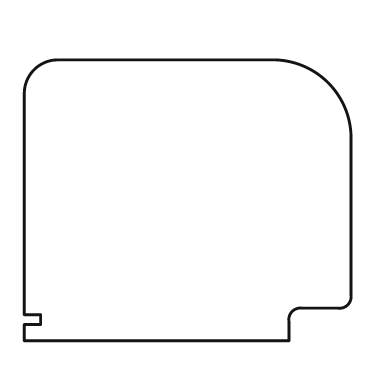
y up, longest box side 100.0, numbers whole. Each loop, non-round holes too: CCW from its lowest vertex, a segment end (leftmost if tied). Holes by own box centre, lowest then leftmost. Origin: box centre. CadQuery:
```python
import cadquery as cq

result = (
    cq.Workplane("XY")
    .moveTo(-50.0, -43.0)
    .lineTo(31.0, -43.0)
    .lineTo(31.0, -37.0)
    .threePointArc((32.0, -34.0), (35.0, -33.0))
    .lineTo(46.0, -33.0)
    .threePointArc((49.0, -32.0), (50.0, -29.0))
    .lineTo(50.0, 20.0)
    .threePointArc((43.0, 36.0), (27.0, 43.0))
    .lineTo(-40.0, 43.0)
    .threePointArc((-47.0, 40.0), (-50.0, 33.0))
    .lineTo(-50.0, -35.0)
    .lineTo(-45.0, -35.0)
    .lineTo(-45.0, -38.0)
    .lineTo(-50.0, -38.0)
    .close()
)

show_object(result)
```